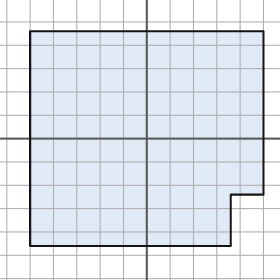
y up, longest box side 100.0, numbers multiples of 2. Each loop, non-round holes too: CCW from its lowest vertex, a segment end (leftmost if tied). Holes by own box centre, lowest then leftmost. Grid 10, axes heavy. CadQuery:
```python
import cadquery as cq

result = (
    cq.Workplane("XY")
    .moveTo(-50.0, -46.0)
    .lineTo(36.0, -46.0)
    .lineTo(36.0, -24.0)
    .lineTo(50.0, -24.0)
    .lineTo(50.0, 46.0)
    .lineTo(-50.0, 46.0)
    .close()
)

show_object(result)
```